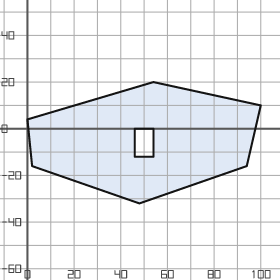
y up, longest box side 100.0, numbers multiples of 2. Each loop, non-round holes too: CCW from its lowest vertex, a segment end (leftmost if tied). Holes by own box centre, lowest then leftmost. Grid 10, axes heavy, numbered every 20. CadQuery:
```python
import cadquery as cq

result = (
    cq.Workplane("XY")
    .moveTo(48.0, -32.0)
    .lineTo(94.0, -16.0)
    .lineTo(100.0, 10.0)
    .lineTo(54.0, 20.0)
    .lineTo(0.0, 4.0)
    .lineTo(2.0, -16.0)
    .close()
    .moveTo(46.0, -12.0)
    .lineTo(54.0, -12.0)
    .lineTo(54.0, 0.0)
    .lineTo(46.0, 0.0)
    .close()
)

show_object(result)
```